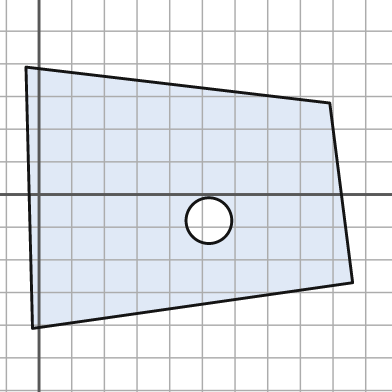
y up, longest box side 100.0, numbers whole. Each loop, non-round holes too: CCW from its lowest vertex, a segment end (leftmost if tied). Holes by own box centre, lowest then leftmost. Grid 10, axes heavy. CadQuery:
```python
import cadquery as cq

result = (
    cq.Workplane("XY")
    .moveTo(-2.0, -41.0)
    .lineTo(96.0, -27.0)
    .lineTo(89.0, 28.0)
    .lineTo(-4.0, 39.0)
    .close()
    .moveTo(52.0, -8.0)
    .circle(7.0)
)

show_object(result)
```